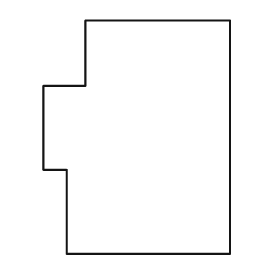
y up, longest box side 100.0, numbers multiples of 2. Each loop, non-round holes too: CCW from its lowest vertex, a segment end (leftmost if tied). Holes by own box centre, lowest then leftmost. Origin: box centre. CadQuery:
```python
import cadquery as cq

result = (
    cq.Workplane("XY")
    .moveTo(-30.0, -50.0)
    .lineTo(40.0, -50.0)
    .lineTo(40.0, 50.0)
    .lineTo(-22.0, 50.0)
    .lineTo(-22.0, 22.0)
    .lineTo(-40.0, 22.0)
    .lineTo(-40.0, -14.0)
    .lineTo(-30.0, -14.0)
    .close()
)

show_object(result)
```